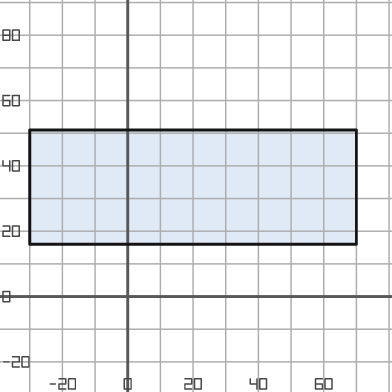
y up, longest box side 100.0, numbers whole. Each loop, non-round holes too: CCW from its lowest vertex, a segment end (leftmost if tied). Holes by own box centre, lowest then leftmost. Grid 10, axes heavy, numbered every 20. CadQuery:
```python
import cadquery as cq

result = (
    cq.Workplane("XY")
    .moveTo(-30.0, 16.0)
    .lineTo(70.0, 16.0)
    .lineTo(70.0, 51.0)
    .lineTo(-30.0, 51.0)
    .close()
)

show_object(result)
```